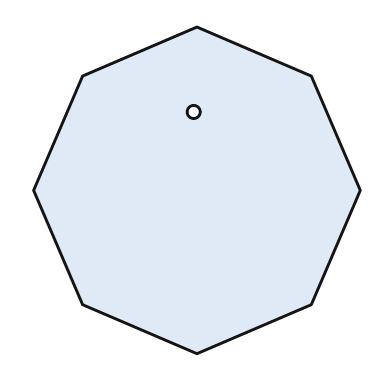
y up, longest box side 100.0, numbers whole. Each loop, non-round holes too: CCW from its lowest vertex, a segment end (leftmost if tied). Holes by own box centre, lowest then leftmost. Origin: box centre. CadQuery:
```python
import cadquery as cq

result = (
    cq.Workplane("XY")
    .moveTo(0.0, -50.0)
    .lineTo(35.0, -35.0)
    .lineTo(50.0, 0.0)
    .lineTo(35.0, 35.0)
    .lineTo(0.0, 50.0)
    .lineTo(-35.0, 35.0)
    .lineTo(-50.0, 0.0)
    .lineTo(-35.0, -35.0)
    .close()
    .moveTo(-1.0, 24.0)
    .circle(2.0)
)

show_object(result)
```